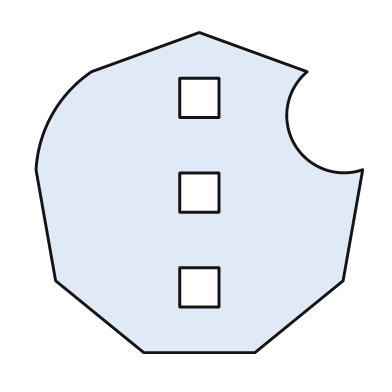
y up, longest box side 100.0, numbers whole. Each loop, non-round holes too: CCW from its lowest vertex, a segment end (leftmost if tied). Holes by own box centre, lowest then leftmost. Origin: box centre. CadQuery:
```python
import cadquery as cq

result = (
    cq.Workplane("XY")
    .moveTo(-17.0, -49.0)
    .lineTo(17.0, -49.0)
    .lineTo(44.0, -27.0)
    .lineTo(50.0, 7.0)
    .threePointArc((29.0, 15.0), (33.0, 37.0))
    .lineTo(0.0, 49.0)
    .lineTo(-33.0, 37.0)
    .threePointArc((-45.0, 24.0), (-50.0, 7.0))
    .lineTo(-44.0, -27.0)
    .close()
    .moveTo(-6.0, -35.0)
    .lineTo(6.0, -35.0)
    .lineTo(6.0, -23.0)
    .lineTo(-6.0, -23.0)
    .close()
    .moveTo(-6.0, -6.0)
    .lineTo(6.0, -6.0)
    .lineTo(6.0, 6.0)
    .lineTo(-6.0, 6.0)
    .close()
    .moveTo(-6.0, 23.0)
    .lineTo(6.0, 23.0)
    .lineTo(6.0, 35.0)
    .lineTo(-6.0, 35.0)
    .close()
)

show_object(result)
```